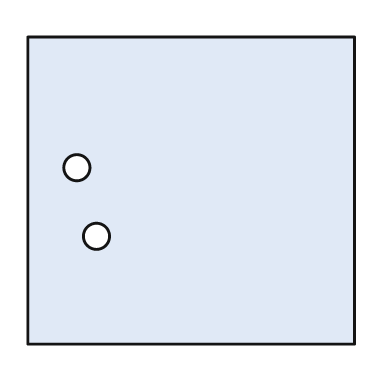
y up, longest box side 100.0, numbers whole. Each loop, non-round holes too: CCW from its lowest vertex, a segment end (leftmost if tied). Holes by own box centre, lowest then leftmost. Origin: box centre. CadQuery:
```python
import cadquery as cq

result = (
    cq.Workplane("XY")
    .moveTo(-50.0, -47.0)
    .lineTo(50.0, -47.0)
    .lineTo(50.0, 47.0)
    .lineTo(-50.0, 47.0)
    .close()
    .moveTo(-29.0, -14.0)
    .circle(4.0)
    .moveTo(-35.0, 7.0)
    .circle(4.0)
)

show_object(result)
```